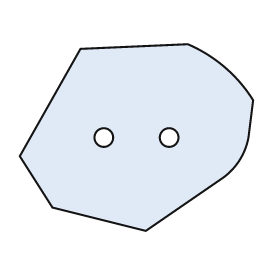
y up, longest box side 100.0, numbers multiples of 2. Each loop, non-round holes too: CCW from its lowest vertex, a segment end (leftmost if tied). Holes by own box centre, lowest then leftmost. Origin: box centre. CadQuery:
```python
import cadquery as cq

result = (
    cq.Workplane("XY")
    .moveTo(4.0, -40.0)
    .lineTo(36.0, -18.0)
    .threePointArc((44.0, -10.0), (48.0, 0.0))
    .lineTo(50.0, 16.0)
    .threePointArc((38.0, 30.0), (22.0, 40.0))
    .lineTo(-24.0, 38.0)
    .lineTo(-50.0, -8.0)
    .lineTo(-36.0, -30.0)
    .close()
    .moveTo(-14.0, 0.0)
    .circle(4.0)
    .moveTo(14.0, 0.0)
    .circle(4.0)
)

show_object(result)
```